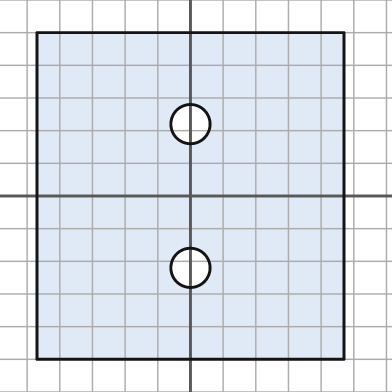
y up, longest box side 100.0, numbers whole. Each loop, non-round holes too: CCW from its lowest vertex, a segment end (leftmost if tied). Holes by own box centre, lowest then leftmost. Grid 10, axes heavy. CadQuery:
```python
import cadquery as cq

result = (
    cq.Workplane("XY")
    .moveTo(-47.0, -50.0)
    .lineTo(47.0, -50.0)
    .lineTo(47.0, 50.0)
    .lineTo(-47.0, 50.0)
    .close()
    .moveTo(0.0, -22.0)
    .circle(6.0)
    .moveTo(0.0, 22.0)
    .circle(6.0)
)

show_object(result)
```